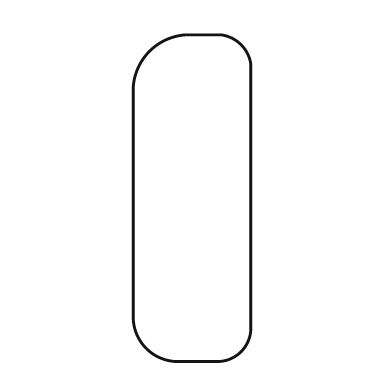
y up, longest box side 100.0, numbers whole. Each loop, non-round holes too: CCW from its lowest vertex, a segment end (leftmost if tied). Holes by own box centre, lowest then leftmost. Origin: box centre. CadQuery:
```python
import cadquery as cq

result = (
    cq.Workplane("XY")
    .moveTo(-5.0, -50.0)
    .lineTo(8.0, -50.0)
    .threePointArc((15.0, -47.0), (18.0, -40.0))
    .lineTo(18.0, 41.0)
    .threePointArc((15.0, 47.0), (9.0, 50.0))
    .lineTo(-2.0, 50.0)
    .threePointArc((-13.0, 45.0), (-18.0, 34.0))
    .lineTo(-18.0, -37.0)
    .threePointArc((-14.0, -46.0), (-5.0, -50.0))
    .close()
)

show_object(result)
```